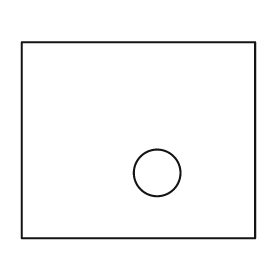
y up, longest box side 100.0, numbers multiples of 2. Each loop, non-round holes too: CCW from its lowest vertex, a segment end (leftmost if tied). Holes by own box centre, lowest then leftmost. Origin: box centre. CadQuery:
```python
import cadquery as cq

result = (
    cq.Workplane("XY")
    .moveTo(-50.0, -42.0)
    .lineTo(50.0, -42.0)
    .lineTo(50.0, 42.0)
    .lineTo(-50.0, 42.0)
    .close()
    .moveTo(8.0, -14.0)
    .circle(10.0)
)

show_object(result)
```